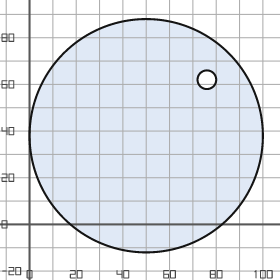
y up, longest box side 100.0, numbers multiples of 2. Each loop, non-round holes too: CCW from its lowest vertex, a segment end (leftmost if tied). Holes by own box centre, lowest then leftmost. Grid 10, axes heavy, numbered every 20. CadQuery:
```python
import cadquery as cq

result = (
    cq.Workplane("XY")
    .moveTo(50.0, 38.0)
    .circle(50.0)
    .moveTo(76.0, 62.0)
    .circle(4.0)
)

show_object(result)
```